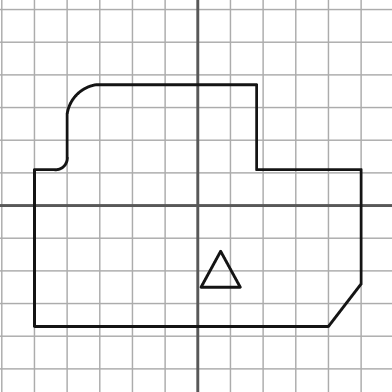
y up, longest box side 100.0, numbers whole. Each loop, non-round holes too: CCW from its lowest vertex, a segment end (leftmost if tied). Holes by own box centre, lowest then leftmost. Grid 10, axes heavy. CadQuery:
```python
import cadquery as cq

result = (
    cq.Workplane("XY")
    .moveTo(-50.0, -37.0)
    .lineTo(40.0, -37.0)
    .lineTo(50.0, -24.0)
    .lineTo(50.0, 11.0)
    .lineTo(18.0, 11.0)
    .lineTo(18.0, 37.0)
    .lineTo(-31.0, 37.0)
    .threePointArc((-37.0, 34.0), (-40.0, 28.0))
    .lineTo(-40.0, 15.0)
    .threePointArc((-41.0, 12.0), (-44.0, 11.0))
    .lineTo(-50.0, 11.0)
    .close()
    .moveTo(1.0, -25.0)
    .lineTo(13.0, -25.0)
    .lineTo(7.0, -14.0)
    .close()
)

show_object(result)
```